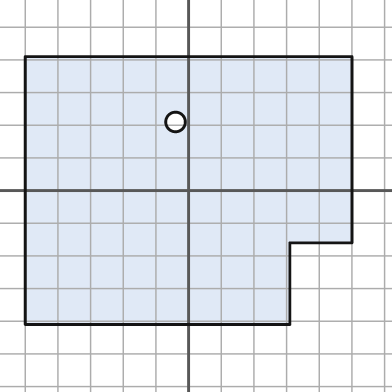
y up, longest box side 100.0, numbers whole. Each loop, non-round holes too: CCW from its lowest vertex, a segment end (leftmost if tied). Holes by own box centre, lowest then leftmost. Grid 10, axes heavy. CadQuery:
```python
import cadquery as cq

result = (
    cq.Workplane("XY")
    .moveTo(-50.0, -41.0)
    .lineTo(31.0, -41.0)
    .lineTo(31.0, -16.0)
    .lineTo(50.0, -16.0)
    .lineTo(50.0, 41.0)
    .lineTo(-50.0, 41.0)
    .close()
    .moveTo(-4.0, 21.0)
    .circle(3.0)
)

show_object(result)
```